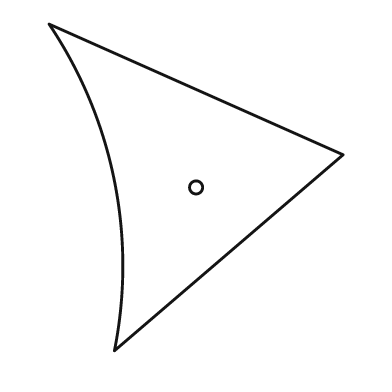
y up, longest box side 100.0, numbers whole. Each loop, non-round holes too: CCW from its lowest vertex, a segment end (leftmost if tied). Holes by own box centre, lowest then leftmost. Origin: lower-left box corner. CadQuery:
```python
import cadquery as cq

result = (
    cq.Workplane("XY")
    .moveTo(20.0, 0.0)
    .lineTo(90.0, 60.0)
    .lineTo(0.0, 100.0)
    .threePointArc((20.0, 52.0), (20.0, 0.0))
    .close()
    .moveTo(45.0, 50.0)
    .circle(2.0)
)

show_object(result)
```